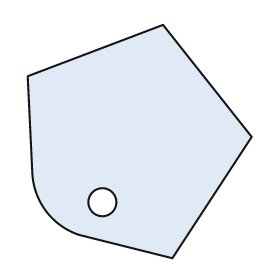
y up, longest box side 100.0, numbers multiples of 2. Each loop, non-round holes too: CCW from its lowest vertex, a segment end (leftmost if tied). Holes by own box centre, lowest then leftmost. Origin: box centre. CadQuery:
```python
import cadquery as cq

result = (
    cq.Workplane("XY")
    .moveTo(14.0, -50.0)
    .lineTo(48.0, 2.0)
    .lineTo(10.0, 50.0)
    .lineTo(-48.0, 28.0)
    .lineTo(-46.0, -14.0)
    .threePointArc((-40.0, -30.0), (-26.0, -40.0))
    .close()
    .moveTo(-16.0, -26.0)
    .circle(6.0)
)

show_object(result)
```